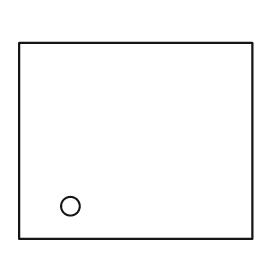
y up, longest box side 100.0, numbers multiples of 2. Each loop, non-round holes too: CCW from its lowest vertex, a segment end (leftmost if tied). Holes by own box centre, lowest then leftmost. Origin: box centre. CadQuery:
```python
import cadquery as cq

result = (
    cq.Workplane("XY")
    .moveTo(-50.0, -42.0)
    .lineTo(50.0, -42.0)
    .lineTo(50.0, 42.0)
    .lineTo(-50.0, 42.0)
    .close()
    .moveTo(-28.0, -28.0)
    .circle(4.0)
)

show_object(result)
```